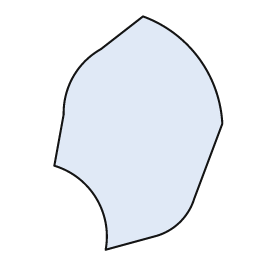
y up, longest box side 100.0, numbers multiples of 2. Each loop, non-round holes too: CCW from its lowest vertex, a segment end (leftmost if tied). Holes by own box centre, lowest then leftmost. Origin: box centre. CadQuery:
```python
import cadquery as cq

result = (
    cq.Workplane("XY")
    .moveTo(-14.0, -50.0)
    .lineTo(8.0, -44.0)
    .threePointArc((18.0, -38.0), (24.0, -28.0))
    .lineTo(36.0, 4.0)
    .threePointArc((26.0, 32.0), (2.0, 50.0))
    .lineTo(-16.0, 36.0)
    .threePointArc((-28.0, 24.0), (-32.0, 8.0))
    .lineTo(-36.0, -14.0)
    .threePointArc((-18.0, -28.0), (-14.0, -50.0))
    .close()
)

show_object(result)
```